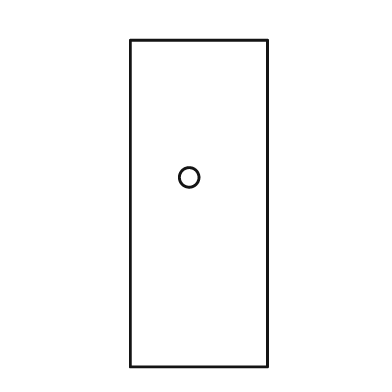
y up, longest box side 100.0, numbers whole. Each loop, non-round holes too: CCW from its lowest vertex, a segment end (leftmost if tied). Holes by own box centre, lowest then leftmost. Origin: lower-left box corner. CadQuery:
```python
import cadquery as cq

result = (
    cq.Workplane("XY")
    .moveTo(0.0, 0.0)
    .lineTo(42.0, 0.0)
    .lineTo(42.0, 100.0)
    .lineTo(0.0, 100.0)
    .close()
    .moveTo(18.0, 58.0)
    .circle(3.0)
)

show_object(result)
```